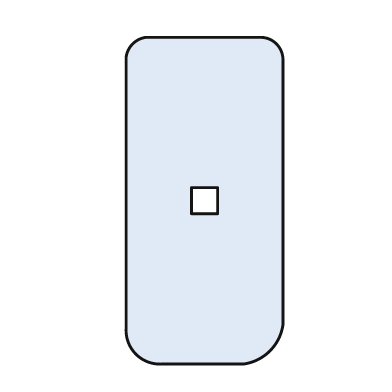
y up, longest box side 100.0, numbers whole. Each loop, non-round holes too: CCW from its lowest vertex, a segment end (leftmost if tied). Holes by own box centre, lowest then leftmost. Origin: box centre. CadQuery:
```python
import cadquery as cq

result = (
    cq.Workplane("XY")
    .moveTo(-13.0, -50.0)
    .lineTo(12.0, -50.0)
    .threePointArc((20.0, -46.0), (24.0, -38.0))
    .lineTo(24.0, 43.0)
    .threePointArc((22.0, 48.0), (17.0, 50.0))
    .lineTo(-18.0, 50.0)
    .threePointArc((-22.0, 48.0), (-24.0, 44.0))
    .lineTo(-24.0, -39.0)
    .threePointArc((-21.0, -47.0), (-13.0, -50.0))
    .close()
    .moveTo(-4.0, -4.0)
    .lineTo(4.0, -4.0)
    .lineTo(4.0, 4.0)
    .lineTo(-4.0, 4.0)
    .close()
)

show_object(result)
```